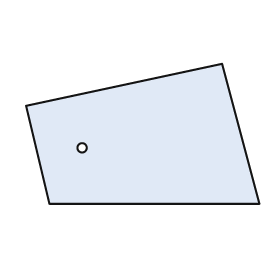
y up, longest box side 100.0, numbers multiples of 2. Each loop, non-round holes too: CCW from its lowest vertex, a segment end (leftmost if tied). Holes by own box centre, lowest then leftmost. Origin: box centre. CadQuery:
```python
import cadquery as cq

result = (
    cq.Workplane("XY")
    .moveTo(-40.0, -30.0)
    .lineTo(50.0, -30.0)
    .lineTo(34.0, 30.0)
    .lineTo(-50.0, 12.0)
    .close()
    .moveTo(-26.0, -6.0)
    .circle(2.0)
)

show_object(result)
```